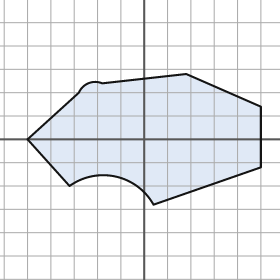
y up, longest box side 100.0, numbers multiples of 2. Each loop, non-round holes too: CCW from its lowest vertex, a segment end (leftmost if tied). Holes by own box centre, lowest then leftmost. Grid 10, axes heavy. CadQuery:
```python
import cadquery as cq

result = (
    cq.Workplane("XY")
    .moveTo(4.0, -28.0)
    .lineTo(50.0, -12.0)
    .lineTo(50.0, 14.0)
    .lineTo(18.0, 28.0)
    .lineTo(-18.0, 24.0)
    .threePointArc((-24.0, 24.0), (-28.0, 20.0))
    .lineTo(-50.0, 0.0)
    .lineTo(-32.0, -20.0)
    .threePointArc((-12.0, -16.0), (4.0, -28.0))
    .close()
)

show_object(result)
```